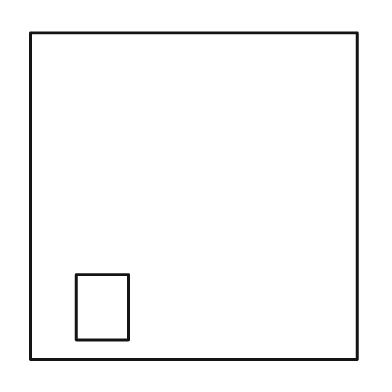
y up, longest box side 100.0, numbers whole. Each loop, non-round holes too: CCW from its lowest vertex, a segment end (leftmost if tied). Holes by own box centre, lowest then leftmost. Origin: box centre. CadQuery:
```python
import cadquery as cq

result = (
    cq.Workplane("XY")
    .moveTo(-50.0, -50.0)
    .lineTo(50.0, -50.0)
    .lineTo(50.0, 50.0)
    .lineTo(-50.0, 50.0)
    .close()
    .moveTo(-36.0, -44.0)
    .lineTo(-20.0, -44.0)
    .lineTo(-20.0, -24.0)
    .lineTo(-36.0, -24.0)
    .close()
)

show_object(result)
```